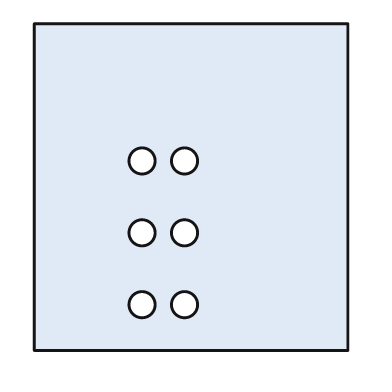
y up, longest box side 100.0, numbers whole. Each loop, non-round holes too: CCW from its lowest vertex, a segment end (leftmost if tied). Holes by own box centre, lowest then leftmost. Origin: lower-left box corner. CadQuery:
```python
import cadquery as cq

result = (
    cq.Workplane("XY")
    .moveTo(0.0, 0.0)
    .lineTo(96.0, 0.0)
    .lineTo(96.0, 100.0)
    .lineTo(0.0, 100.0)
    .close()
    .moveTo(33.0, 14.0)
    .circle(4.0)
    .moveTo(46.0, 14.0)
    .circle(4.0)
    .moveTo(33.0, 36.0)
    .circle(4.0)
    .moveTo(46.0, 36.0)
    .circle(4.0)
    .moveTo(33.0, 58.0)
    .circle(4.0)
    .moveTo(46.0, 58.0)
    .circle(4.0)
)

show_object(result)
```